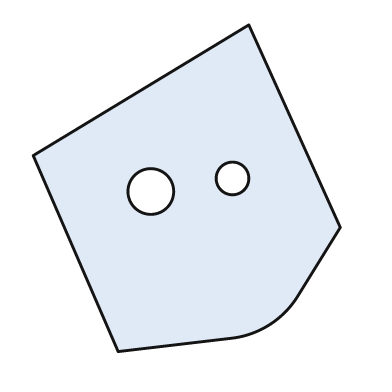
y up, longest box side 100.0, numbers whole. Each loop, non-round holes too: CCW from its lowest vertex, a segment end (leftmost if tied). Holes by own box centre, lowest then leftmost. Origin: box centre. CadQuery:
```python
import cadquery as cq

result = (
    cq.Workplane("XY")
    .moveTo(-21.0, -50.0)
    .lineTo(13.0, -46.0)
    .threePointArc((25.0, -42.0), (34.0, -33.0))
    .lineTo(47.0, -12.0)
    .lineTo(19.0, 50.0)
    .lineTo(-47.0, 10.0)
    .close()
    .moveTo(-11.0, -1.0)
    .circle(7.0)
    .moveTo(14.0, 3.0)
    .circle(5.0)
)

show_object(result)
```